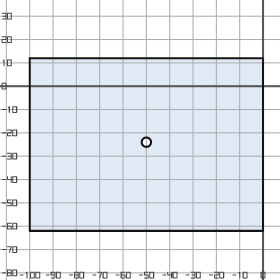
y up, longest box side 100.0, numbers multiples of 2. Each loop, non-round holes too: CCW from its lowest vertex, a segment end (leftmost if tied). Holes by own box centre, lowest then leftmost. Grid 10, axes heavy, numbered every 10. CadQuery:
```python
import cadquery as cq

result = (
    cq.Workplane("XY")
    .moveTo(-100.0, -62.0)
    .lineTo(0.0, -62.0)
    .lineTo(0.0, 12.0)
    .lineTo(-100.0, 12.0)
    .close()
    .moveTo(-50.0, -24.0)
    .circle(2.0)
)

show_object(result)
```